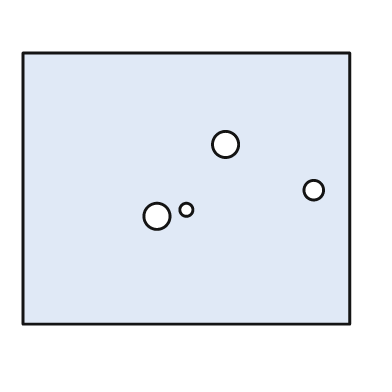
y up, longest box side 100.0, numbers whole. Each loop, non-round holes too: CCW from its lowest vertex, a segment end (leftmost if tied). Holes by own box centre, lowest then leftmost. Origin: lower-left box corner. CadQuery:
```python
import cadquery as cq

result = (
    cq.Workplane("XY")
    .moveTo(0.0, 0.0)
    .lineTo(100.0, 0.0)
    .lineTo(100.0, 83.0)
    .lineTo(0.0, 83.0)
    .close()
    .moveTo(41.0, 33.0)
    .circle(4.0)
    .moveTo(50.0, 35.0)
    .circle(2.0)
    .moveTo(89.0, 41.0)
    .circle(3.0)
    .moveTo(62.0, 55.0)
    .circle(4.0)
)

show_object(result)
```